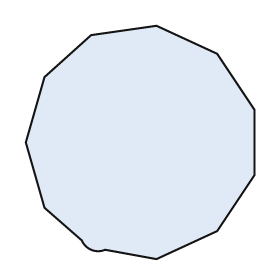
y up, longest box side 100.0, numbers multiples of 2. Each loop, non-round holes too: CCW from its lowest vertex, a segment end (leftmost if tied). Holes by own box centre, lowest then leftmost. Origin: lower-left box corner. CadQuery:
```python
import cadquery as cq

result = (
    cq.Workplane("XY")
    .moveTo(56.0, 0.0)
    .lineTo(82.0, 12.0)
    .lineTo(98.0, 36.0)
    .lineTo(98.0, 64.0)
    .lineTo(82.0, 88.0)
    .lineTo(56.0, 100.0)
    .lineTo(28.0, 96.0)
    .lineTo(8.0, 78.0)
    .lineTo(0.0, 50.0)
    .lineTo(8.0, 22.0)
    .lineTo(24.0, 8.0)
    .threePointArc((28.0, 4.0), (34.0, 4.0))
    .close()
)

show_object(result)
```